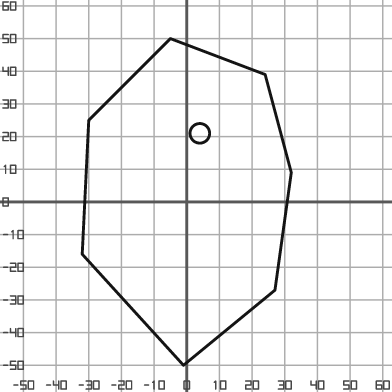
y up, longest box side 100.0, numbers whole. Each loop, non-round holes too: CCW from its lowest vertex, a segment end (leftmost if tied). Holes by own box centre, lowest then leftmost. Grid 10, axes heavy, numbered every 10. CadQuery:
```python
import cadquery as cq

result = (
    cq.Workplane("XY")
    .moveTo(-1.0, -50.0)
    .lineTo(27.0, -27.0)
    .lineTo(32.0, 9.0)
    .lineTo(24.0, 39.0)
    .lineTo(-5.0, 50.0)
    .lineTo(-30.0, 25.0)
    .lineTo(-32.0, -16.0)
    .close()
    .moveTo(4.0, 21.0)
    .circle(3.0)
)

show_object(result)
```